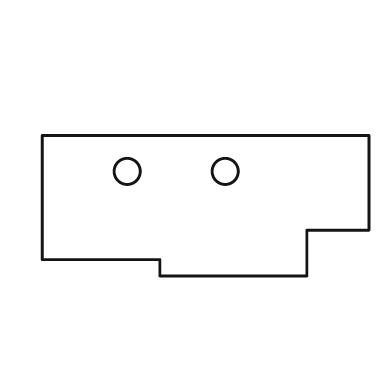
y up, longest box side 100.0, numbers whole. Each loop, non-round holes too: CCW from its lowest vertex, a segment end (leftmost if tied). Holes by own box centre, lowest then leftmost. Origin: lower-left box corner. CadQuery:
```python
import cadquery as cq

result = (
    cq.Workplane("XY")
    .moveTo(36.0, 0.0)
    .lineTo(81.0, 0.0)
    .lineTo(81.0, 14.0)
    .lineTo(100.0, 14.0)
    .lineTo(100.0, 43.0)
    .lineTo(0.0, 43.0)
    .lineTo(0.0, 5.0)
    .lineTo(36.0, 5.0)
    .close()
    .moveTo(26.0, 32.0)
    .circle(4.0)
    .moveTo(56.0, 32.0)
    .circle(4.0)
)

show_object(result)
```